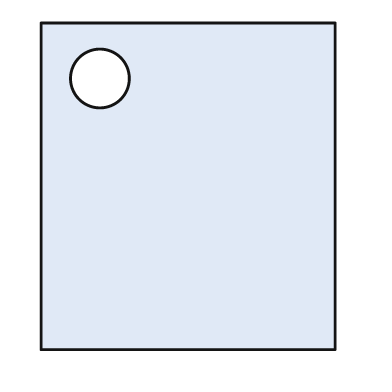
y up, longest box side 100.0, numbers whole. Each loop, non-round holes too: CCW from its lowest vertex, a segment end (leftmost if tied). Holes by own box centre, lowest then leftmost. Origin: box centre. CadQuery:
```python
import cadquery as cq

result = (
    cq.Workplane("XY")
    .moveTo(-45.0, -50.0)
    .lineTo(45.0, -50.0)
    .lineTo(45.0, 50.0)
    .lineTo(-45.0, 50.0)
    .close()
    .moveTo(-27.0, 33.0)
    .circle(9.0)
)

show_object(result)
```